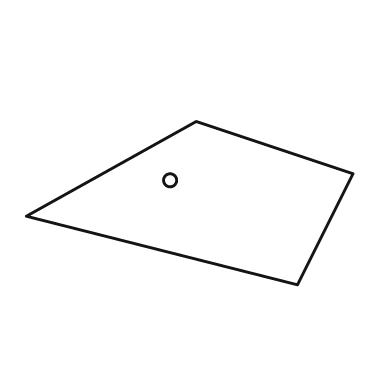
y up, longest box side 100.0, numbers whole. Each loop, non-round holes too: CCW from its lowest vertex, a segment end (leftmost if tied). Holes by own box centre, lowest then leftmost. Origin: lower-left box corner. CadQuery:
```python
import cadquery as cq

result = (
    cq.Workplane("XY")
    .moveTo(83.0, 0.0)
    .lineTo(100.0, 34.0)
    .lineTo(52.0, 50.0)
    .lineTo(0.0, 21.0)
    .close()
    .moveTo(44.0, 32.0)
    .circle(2.0)
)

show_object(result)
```